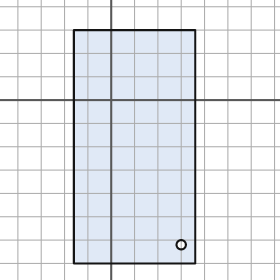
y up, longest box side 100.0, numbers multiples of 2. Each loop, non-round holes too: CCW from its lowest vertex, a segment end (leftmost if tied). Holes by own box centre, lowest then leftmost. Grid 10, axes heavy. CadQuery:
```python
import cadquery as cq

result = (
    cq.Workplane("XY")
    .moveTo(-16.0, -70.0)
    .lineTo(36.0, -70.0)
    .lineTo(36.0, 30.0)
    .lineTo(-16.0, 30.0)
    .close()
    .moveTo(30.0, -62.0)
    .circle(2.0)
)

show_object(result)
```